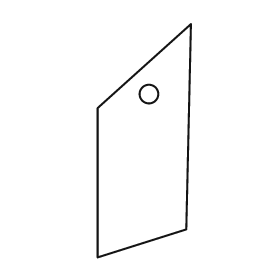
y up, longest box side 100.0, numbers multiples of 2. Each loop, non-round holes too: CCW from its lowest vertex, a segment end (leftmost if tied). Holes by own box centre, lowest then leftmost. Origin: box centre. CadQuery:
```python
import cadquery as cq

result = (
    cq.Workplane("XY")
    .moveTo(-20.0, -50.0)
    .lineTo(18.0, -38.0)
    .lineTo(20.0, 50.0)
    .lineTo(-20.0, 14.0)
    .close()
    .moveTo(2.0, 20.0)
    .circle(4.0)
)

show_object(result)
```